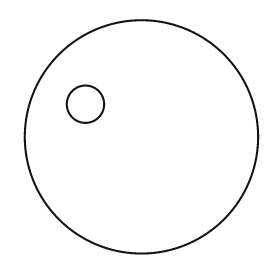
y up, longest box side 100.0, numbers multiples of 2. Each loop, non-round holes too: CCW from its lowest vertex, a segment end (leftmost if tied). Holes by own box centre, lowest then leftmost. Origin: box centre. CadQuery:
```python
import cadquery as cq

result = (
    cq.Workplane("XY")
    .moveTo(0.0, 0.0)
    .circle(50.0)
    .moveTo(-24.0, 14.0)
    .circle(8.0)
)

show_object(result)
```